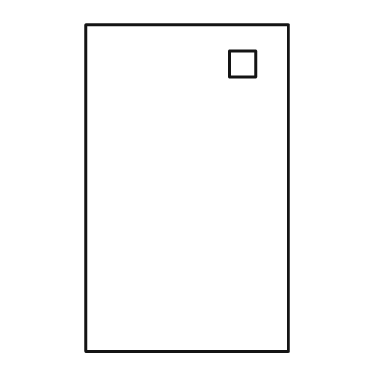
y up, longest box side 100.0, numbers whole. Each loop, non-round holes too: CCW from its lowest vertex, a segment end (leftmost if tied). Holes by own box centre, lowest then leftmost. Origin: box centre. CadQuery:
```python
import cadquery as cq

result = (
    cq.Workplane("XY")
    .moveTo(-31.0, -50.0)
    .lineTo(31.0, -50.0)
    .lineTo(31.0, 50.0)
    .lineTo(-31.0, 50.0)
    .close()
    .moveTo(13.0, 34.0)
    .lineTo(21.0, 34.0)
    .lineTo(21.0, 42.0)
    .lineTo(13.0, 42.0)
    .close()
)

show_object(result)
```